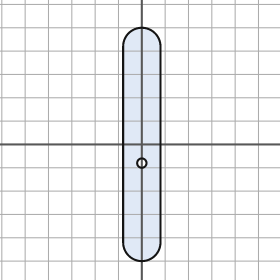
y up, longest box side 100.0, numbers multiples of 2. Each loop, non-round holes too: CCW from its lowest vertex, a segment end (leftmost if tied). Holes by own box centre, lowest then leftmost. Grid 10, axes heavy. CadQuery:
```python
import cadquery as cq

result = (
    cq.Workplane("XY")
    .moveTo(-8.0, -42.0)
    .threePointArc((0.0, -50.0), (8.0, -42.0))
    .lineTo(8.0, 42.0)
    .threePointArc((0.0, 50.0), (-8.0, 42.0))
    .close()
    .moveTo(0.0, -8.0)
    .circle(2.0)
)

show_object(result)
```